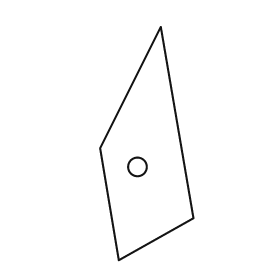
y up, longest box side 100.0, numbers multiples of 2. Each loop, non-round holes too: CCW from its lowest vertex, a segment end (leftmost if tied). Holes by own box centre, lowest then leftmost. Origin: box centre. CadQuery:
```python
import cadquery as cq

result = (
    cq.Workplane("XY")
    .moveTo(-12.0, -50.0)
    .lineTo(20.0, -32.0)
    .lineTo(6.0, 50.0)
    .lineTo(-20.0, -2.0)
    .close()
    .moveTo(-4.0, -10.0)
    .circle(4.0)
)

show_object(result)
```